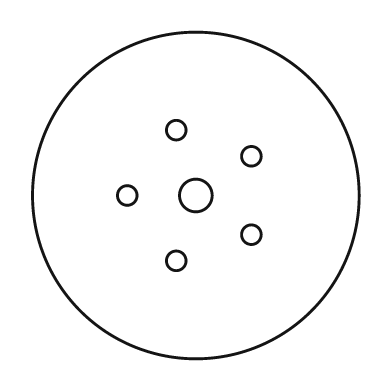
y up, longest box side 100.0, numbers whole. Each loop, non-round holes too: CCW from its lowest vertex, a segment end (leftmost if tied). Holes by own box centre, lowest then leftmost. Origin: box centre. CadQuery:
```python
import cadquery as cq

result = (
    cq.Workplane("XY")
    .moveTo(0.0, 0.0)
    .circle(50.0)
    .moveTo(-6.0, -20.0)
    .circle(3.0)
    .moveTo(17.0, -12.0)
    .circle(3.0)
    .moveTo(-21.0, 0.0)
    .circle(3.0)
    .moveTo(0.0, 0.0)
    .circle(5.0)
    .moveTo(17.0, 12.0)
    .circle(3.0)
    .moveTo(-6.0, 20.0)
    .circle(3.0)
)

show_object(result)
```